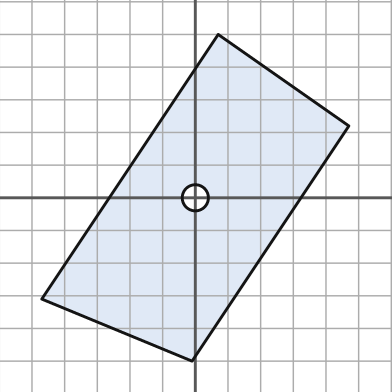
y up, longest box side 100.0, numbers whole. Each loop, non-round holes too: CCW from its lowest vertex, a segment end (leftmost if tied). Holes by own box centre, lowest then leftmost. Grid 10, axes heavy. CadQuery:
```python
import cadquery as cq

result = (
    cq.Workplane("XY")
    .moveTo(-1.0, -50.0)
    .lineTo(47.0, 22.0)
    .lineTo(7.0, 50.0)
    .lineTo(-47.0, -31.0)
    .close()
    .moveTo(0.0, 0.0)
    .circle(4.0)
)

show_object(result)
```